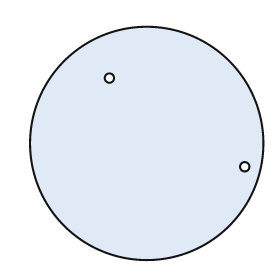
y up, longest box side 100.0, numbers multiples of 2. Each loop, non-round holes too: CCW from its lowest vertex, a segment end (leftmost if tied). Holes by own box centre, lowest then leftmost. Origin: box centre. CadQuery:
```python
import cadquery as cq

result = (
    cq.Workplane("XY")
    .moveTo(0.0, 0.0)
    .circle(50.0)
    .moveTo(42.0, -10.0)
    .circle(2.0)
    .moveTo(-16.0, 28.0)
    .circle(2.0)
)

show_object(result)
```